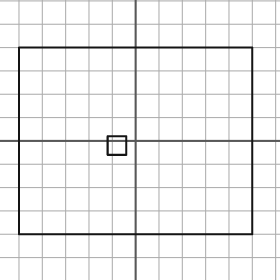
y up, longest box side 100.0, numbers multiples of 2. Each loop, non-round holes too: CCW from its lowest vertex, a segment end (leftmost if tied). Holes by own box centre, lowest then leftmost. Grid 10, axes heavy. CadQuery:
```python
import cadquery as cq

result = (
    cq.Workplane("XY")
    .moveTo(-50.0, -40.0)
    .lineTo(50.0, -40.0)
    .lineTo(50.0, 40.0)
    .lineTo(-50.0, 40.0)
    .close()
    .moveTo(-12.0, -6.0)
    .lineTo(-4.0, -6.0)
    .lineTo(-4.0, 2.0)
    .lineTo(-12.0, 2.0)
    .close()
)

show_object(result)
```